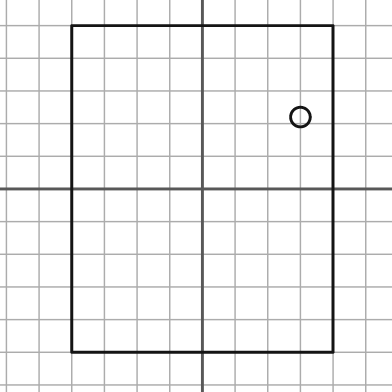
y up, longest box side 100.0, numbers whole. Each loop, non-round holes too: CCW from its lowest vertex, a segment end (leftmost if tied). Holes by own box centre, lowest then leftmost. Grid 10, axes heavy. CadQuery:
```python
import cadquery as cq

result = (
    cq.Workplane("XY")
    .moveTo(-40.0, -50.0)
    .lineTo(40.0, -50.0)
    .lineTo(40.0, 50.0)
    .lineTo(-40.0, 50.0)
    .close()
    .moveTo(30.0, 22.0)
    .circle(3.0)
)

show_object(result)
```